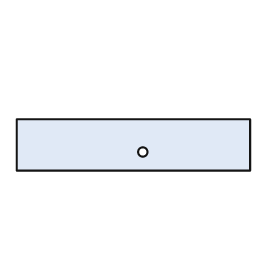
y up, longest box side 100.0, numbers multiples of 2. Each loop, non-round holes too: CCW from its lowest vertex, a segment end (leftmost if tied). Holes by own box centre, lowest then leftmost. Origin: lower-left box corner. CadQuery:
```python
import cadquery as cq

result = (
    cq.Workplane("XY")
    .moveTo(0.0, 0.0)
    .lineTo(100.0, 0.0)
    .lineTo(100.0, 22.0)
    .lineTo(0.0, 22.0)
    .close()
    .moveTo(54.0, 8.0)
    .circle(2.0)
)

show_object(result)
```